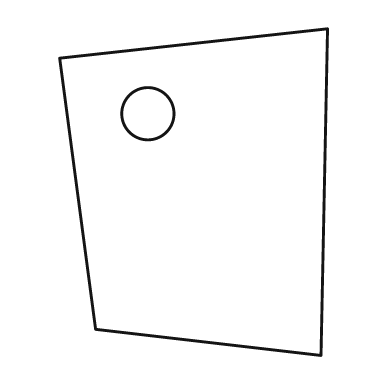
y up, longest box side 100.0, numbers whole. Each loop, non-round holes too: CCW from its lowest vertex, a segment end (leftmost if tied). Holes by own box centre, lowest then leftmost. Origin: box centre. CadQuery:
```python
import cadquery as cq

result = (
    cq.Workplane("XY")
    .moveTo(39.0, -50.0)
    .lineTo(41.0, 50.0)
    .lineTo(-41.0, 41.0)
    .lineTo(-30.0, -42.0)
    .close()
    .moveTo(-14.0, 24.0)
    .circle(8.0)
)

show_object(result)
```